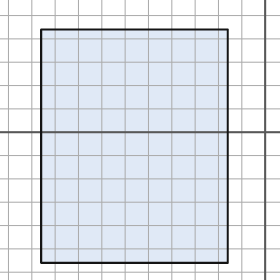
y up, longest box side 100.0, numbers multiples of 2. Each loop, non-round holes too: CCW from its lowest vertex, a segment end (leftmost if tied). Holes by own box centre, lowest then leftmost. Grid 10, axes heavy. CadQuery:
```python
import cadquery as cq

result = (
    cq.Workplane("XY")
    .moveTo(-96.0, -56.0)
    .lineTo(-16.0, -56.0)
    .lineTo(-16.0, 44.0)
    .lineTo(-96.0, 44.0)
    .close()
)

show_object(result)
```